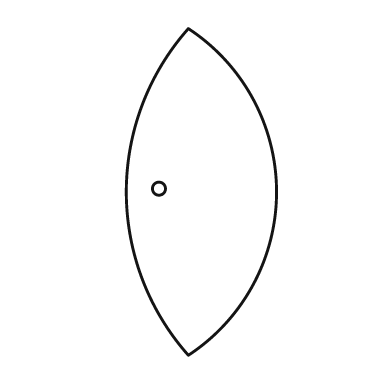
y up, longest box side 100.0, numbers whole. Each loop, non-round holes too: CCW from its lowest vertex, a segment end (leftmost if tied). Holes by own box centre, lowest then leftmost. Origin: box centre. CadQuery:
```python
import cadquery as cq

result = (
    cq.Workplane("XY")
    .moveTo(-4.0, -50.0)
    .threePointArc((23.0, 0.0), (-4.0, 50.0))
    .threePointArc((-23.0, 0.0), (-4.0, -50.0))
    .close()
    .moveTo(-13.0, 1.0)
    .circle(2.0)
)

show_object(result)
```